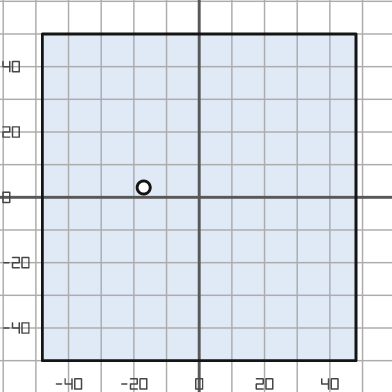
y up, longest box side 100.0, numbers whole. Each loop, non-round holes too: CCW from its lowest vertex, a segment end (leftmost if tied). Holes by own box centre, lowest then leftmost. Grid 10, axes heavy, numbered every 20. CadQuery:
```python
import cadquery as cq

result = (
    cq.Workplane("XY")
    .moveTo(-48.0, -50.0)
    .lineTo(48.0, -50.0)
    .lineTo(48.0, 50.0)
    .lineTo(-48.0, 50.0)
    .close()
    .moveTo(-17.0, 3.0)
    .circle(2.0)
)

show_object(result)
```